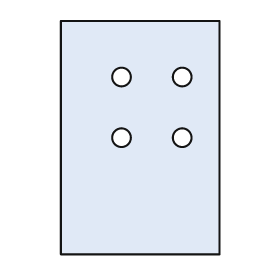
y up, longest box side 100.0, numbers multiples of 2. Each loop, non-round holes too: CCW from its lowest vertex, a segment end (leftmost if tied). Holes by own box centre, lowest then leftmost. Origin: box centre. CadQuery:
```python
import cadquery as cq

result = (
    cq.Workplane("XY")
    .moveTo(-34.0, -50.0)
    .lineTo(34.0, -50.0)
    .lineTo(34.0, 50.0)
    .lineTo(-34.0, 50.0)
    .close()
    .moveTo(-8.0, 0.0)
    .circle(4.0)
    .moveTo(18.0, 0.0)
    .circle(4.0)
    .moveTo(-8.0, 26.0)
    .circle(4.0)
    .moveTo(18.0, 26.0)
    .circle(4.0)
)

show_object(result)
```